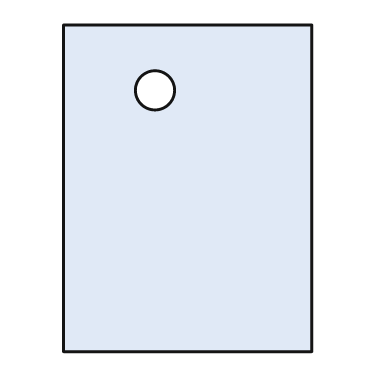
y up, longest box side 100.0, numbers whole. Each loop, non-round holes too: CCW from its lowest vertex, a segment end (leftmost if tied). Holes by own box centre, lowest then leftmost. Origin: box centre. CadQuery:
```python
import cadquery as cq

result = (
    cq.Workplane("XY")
    .moveTo(-38.0, -50.0)
    .lineTo(38.0, -50.0)
    .lineTo(38.0, 50.0)
    .lineTo(-38.0, 50.0)
    .close()
    .moveTo(-10.0, 30.0)
    .circle(6.0)
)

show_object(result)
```